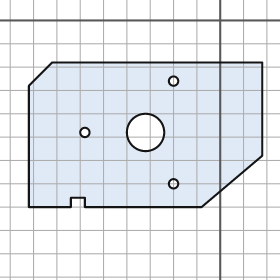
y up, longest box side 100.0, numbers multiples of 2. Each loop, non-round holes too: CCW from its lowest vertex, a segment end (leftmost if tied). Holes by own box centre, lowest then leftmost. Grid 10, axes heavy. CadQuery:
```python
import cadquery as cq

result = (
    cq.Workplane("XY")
    .moveTo(-82.0, -80.0)
    .lineTo(-64.0, -80.0)
    .lineTo(-64.0, -76.0)
    .lineTo(-58.0, -76.0)
    .lineTo(-58.0, -80.0)
    .lineTo(-8.0, -80.0)
    .lineTo(18.0, -58.0)
    .lineTo(18.0, -18.0)
    .lineTo(-72.0, -18.0)
    .lineTo(-82.0, -28.0)
    .close()
    .moveTo(-20.0, -70.0)
    .circle(2.0)
    .moveTo(-58.0, -48.0)
    .circle(2.0)
    .moveTo(-32.0, -48.0)
    .circle(8.0)
    .moveTo(-20.0, -26.0)
    .circle(2.0)
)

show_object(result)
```